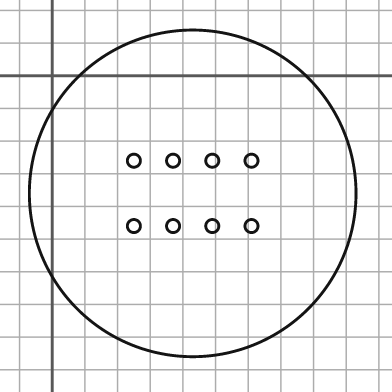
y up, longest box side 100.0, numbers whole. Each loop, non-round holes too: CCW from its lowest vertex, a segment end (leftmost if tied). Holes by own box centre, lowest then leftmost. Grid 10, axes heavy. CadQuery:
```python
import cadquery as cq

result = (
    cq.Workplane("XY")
    .moveTo(43.0, -36.0)
    .circle(50.0)
    .moveTo(25.0, -46.0)
    .circle(2.0)
    .moveTo(37.0, -46.0)
    .circle(2.0)
    .moveTo(49.0, -46.0)
    .circle(2.0)
    .moveTo(61.0, -46.0)
    .circle(2.0)
    .moveTo(25.0, -26.0)
    .circle(2.0)
    .moveTo(37.0, -26.0)
    .circle(2.0)
    .moveTo(49.0, -26.0)
    .circle(2.0)
    .moveTo(61.0, -26.0)
    .circle(2.0)
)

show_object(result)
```